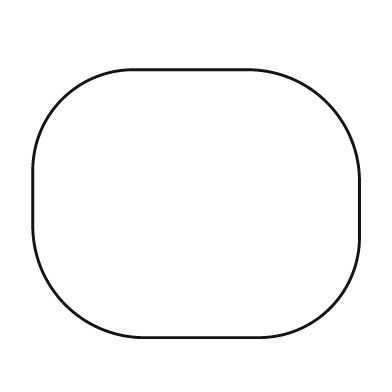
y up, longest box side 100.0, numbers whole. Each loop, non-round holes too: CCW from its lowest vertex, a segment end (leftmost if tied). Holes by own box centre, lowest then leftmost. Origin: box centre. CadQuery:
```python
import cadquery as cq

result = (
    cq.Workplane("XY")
    .moveTo(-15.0, -41.0)
    .lineTo(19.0, -41.0)
    .threePointArc((41.0, -32.0), (50.0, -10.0))
    .lineTo(50.0, 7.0)
    .threePointArc((40.0, 31.0), (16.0, 41.0))
    .lineTo(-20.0, 41.0)
    .threePointArc((-41.0, 32.0), (-50.0, 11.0))
    .lineTo(-50.0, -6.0)
    .threePointArc((-40.0, -31.0), (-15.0, -41.0))
    .close()
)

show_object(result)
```